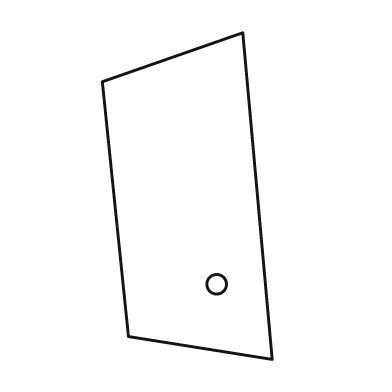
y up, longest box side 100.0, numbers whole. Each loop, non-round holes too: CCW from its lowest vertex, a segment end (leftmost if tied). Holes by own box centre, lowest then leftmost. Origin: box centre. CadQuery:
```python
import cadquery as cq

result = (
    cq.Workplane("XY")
    .moveTo(26.0, -50.0)
    .lineTo(17.0, 50.0)
    .lineTo(-26.0, 35.0)
    .lineTo(-18.0, -43.0)
    .close()
    .moveTo(9.0, -27.0)
    .circle(3.0)
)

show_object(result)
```